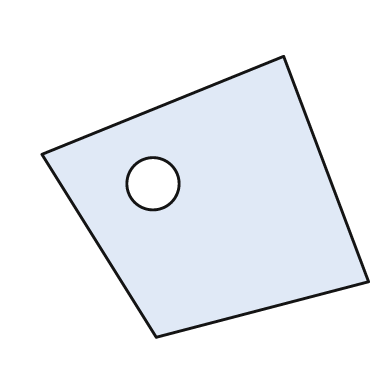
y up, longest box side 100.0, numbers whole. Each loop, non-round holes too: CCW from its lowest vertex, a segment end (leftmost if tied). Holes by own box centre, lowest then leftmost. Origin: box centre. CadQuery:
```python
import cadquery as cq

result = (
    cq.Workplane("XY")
    .moveTo(-15.0, -43.0)
    .lineTo(50.0, -26.0)
    .lineTo(24.0, 43.0)
    .lineTo(-50.0, 13.0)
    .close()
    .moveTo(-16.0, 4.0)
    .circle(8.0)
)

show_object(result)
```